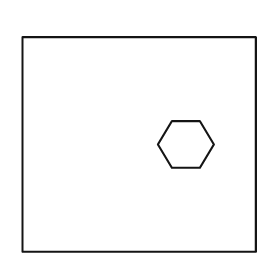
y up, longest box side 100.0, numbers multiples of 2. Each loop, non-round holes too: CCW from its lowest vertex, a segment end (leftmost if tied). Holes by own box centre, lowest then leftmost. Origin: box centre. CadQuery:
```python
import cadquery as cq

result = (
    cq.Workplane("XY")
    .moveTo(-50.0, -46.0)
    .lineTo(50.0, -46.0)
    .lineTo(50.0, 46.0)
    .lineTo(-50.0, 46.0)
    .close()
    .moveTo(14.0, -10.0)
    .lineTo(26.0, -10.0)
    .lineTo(32.0, 0.0)
    .lineTo(26.0, 10.0)
    .lineTo(14.0, 10.0)
    .lineTo(8.0, 0.0)
    .close()
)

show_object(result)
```